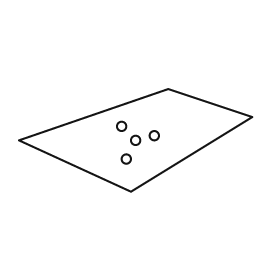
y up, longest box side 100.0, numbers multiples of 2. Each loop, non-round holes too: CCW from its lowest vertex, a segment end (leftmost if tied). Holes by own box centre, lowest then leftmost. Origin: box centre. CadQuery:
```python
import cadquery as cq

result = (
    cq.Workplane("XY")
    .moveTo(-2.0, -22.0)
    .lineTo(50.0, 10.0)
    .lineTo(14.0, 22.0)
    .lineTo(-50.0, 0.0)
    .close()
    .moveTo(-4.0, -8.0)
    .circle(2.0)
    .moveTo(0.0, 0.0)
    .circle(2.0)
    .moveTo(8.0, 2.0)
    .circle(2.0)
    .moveTo(-6.0, 6.0)
    .circle(2.0)
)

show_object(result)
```